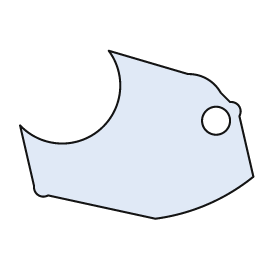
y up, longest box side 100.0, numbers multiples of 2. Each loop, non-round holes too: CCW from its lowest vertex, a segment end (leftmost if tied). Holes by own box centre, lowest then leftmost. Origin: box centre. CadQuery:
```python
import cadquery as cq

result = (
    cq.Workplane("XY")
    .moveTo(8.0, -36.0)
    .threePointArc((30.0, -30.0), (50.0, -18.0))
    .lineTo(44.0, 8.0)
    .threePointArc((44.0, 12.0), (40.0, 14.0))
    .lineTo(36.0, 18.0)
    .threePointArc((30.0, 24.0), (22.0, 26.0))
    .lineTo(-12.0, 36.0)
    .threePointArc((-16.0, 2.0), (-50.0, 4.0))
    .lineTo(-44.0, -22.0)
    .threePointArc((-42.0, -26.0), (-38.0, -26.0))
    .close()
    .moveTo(34.0, 6.0)
    .circle(6.0)
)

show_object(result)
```